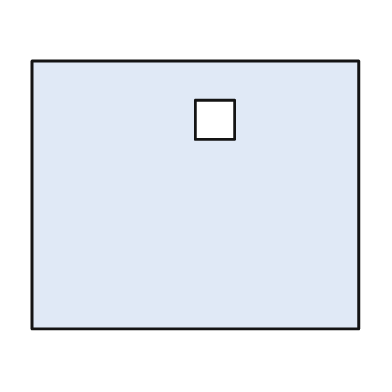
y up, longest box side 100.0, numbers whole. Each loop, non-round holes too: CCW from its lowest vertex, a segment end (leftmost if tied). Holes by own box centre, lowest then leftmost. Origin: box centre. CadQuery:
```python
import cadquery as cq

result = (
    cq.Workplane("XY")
    .moveTo(-50.0, -41.0)
    .lineTo(50.0, -41.0)
    .lineTo(50.0, 41.0)
    .lineTo(-50.0, 41.0)
    .close()
    .moveTo(0.0, 17.0)
    .lineTo(12.0, 17.0)
    .lineTo(12.0, 29.0)
    .lineTo(0.0, 29.0)
    .close()
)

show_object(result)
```